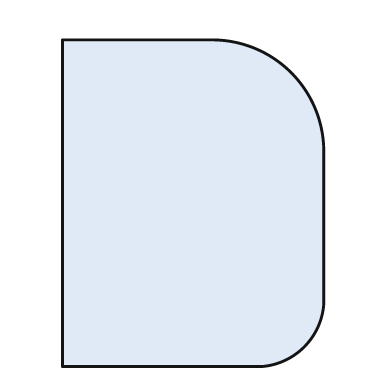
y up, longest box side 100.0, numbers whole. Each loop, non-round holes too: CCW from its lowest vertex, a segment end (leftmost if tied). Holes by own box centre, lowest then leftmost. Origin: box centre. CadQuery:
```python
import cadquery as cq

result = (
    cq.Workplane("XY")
    .moveTo(-40.0, -50.0)
    .lineTo(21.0, -50.0)
    .threePointArc((34.0, -44.0), (40.0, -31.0))
    .lineTo(40.0, 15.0)
    .threePointArc((30.0, 40.0), (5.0, 50.0))
    .lineTo(-40.0, 50.0)
    .close()
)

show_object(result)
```